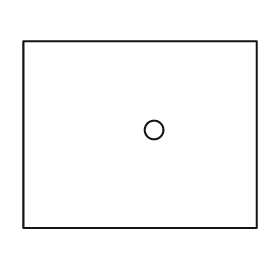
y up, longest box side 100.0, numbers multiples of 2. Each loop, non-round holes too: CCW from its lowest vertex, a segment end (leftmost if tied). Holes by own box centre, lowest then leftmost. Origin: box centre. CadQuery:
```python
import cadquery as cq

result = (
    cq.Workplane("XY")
    .moveTo(-50.0, -40.0)
    .lineTo(50.0, -40.0)
    .lineTo(50.0, 40.0)
    .lineTo(-50.0, 40.0)
    .close()
    .moveTo(6.0, 2.0)
    .circle(4.0)
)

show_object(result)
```